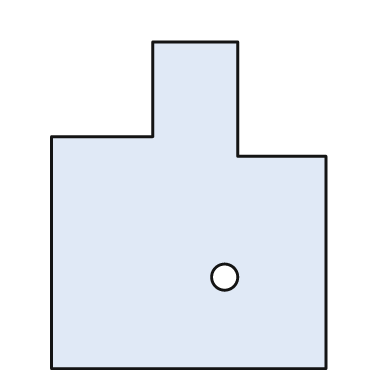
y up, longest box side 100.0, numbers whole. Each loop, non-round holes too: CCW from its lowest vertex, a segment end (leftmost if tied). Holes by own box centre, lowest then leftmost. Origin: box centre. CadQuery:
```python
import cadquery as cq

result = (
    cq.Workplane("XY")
    .moveTo(-42.0, -50.0)
    .lineTo(42.0, -50.0)
    .lineTo(42.0, 15.0)
    .lineTo(15.0, 15.0)
    .lineTo(15.0, 50.0)
    .lineTo(-11.0, 50.0)
    .lineTo(-11.0, 21.0)
    .lineTo(-42.0, 21.0)
    .close()
    .moveTo(11.0, -22.0)
    .circle(4.0)
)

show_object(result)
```